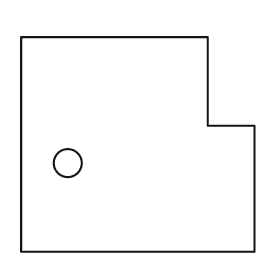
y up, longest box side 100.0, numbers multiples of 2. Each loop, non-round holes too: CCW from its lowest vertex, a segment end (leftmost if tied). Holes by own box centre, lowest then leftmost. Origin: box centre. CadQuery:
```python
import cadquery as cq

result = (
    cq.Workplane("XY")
    .moveTo(-50.0, -46.0)
    .lineTo(50.0, -46.0)
    .lineTo(50.0, 8.0)
    .lineTo(30.0, 8.0)
    .lineTo(30.0, 46.0)
    .lineTo(-50.0, 46.0)
    .close()
    .moveTo(-30.0, -8.0)
    .circle(6.0)
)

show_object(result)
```